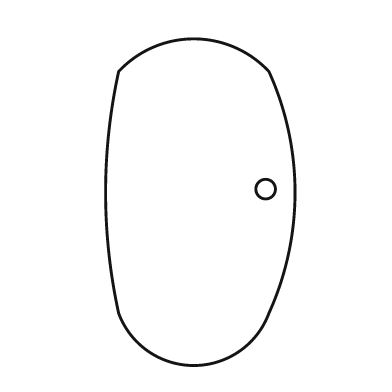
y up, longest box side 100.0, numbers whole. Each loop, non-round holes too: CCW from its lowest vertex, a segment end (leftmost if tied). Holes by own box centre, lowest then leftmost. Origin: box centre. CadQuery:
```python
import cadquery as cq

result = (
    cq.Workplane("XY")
    .moveTo(-25.0, -34.0)
    .threePointArc((-2.0, -50.0), (21.0, -34.0))
    .threePointArc((29.0, 3.0), (21.0, 40.0))
    .threePointArc((-2.0, 50.0), (-25.0, 40.0))
    .threePointArc((-29.0, 3.0), (-25.0, -34.0))
    .close()
    .moveTo(20.0, 4.0)
    .circle(3.0)
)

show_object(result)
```